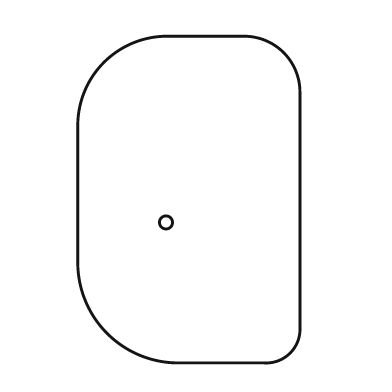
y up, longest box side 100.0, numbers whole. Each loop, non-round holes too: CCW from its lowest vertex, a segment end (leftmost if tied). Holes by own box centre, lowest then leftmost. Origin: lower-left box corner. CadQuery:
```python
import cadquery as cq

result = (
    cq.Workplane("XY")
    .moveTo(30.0, 0.0)
    .lineTo(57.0, 0.0)
    .threePointArc((65.0, 3.0), (68.0, 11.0))
    .lineTo(68.0, 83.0)
    .threePointArc((63.0, 95.0), (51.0, 100.0))
    .lineTo(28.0, 100.0)
    .threePointArc((8.0, 92.0), (0.0, 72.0))
    .lineTo(0.0, 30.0)
    .threePointArc((9.0, 9.0), (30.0, 0.0))
    .close()
    .moveTo(27.0, 43.0)
    .circle(2.0)
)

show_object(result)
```